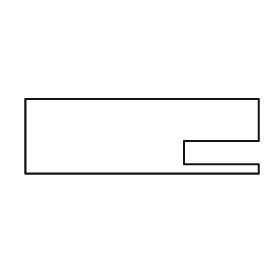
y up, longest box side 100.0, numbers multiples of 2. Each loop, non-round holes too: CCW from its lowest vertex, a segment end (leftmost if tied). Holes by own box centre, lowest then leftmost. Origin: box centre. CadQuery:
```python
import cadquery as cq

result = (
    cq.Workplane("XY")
    .moveTo(-50.0, -16.0)
    .lineTo(50.0, -16.0)
    .lineTo(50.0, -12.0)
    .lineTo(18.0, -12.0)
    .lineTo(18.0, -2.0)
    .lineTo(50.0, -2.0)
    .lineTo(50.0, 16.0)
    .lineTo(-50.0, 16.0)
    .close()
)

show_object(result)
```